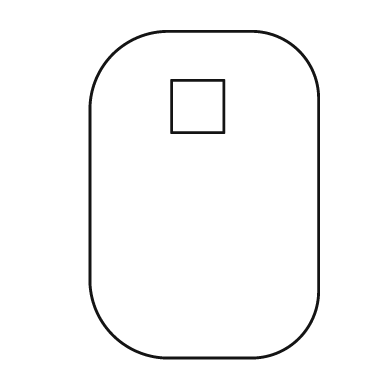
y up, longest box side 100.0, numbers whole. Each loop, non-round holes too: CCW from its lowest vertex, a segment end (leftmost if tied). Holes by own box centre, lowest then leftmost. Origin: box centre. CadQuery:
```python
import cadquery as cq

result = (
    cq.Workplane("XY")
    .moveTo(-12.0, -50.0)
    .lineTo(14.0, -50.0)
    .threePointArc((29.0, -44.0), (35.0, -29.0))
    .lineTo(35.0, 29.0)
    .threePointArc((29.0, 44.0), (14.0, 50.0))
    .lineTo(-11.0, 50.0)
    .threePointArc((-28.0, 43.0), (-35.0, 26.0))
    .lineTo(-35.0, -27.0)
    .threePointArc((-28.0, -43.0), (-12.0, -50.0))
    .close()
    .moveTo(-10.0, 19.0)
    .lineTo(6.0, 19.0)
    .lineTo(6.0, 35.0)
    .lineTo(-10.0, 35.0)
    .close()
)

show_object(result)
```